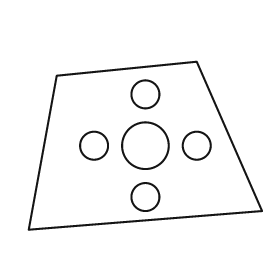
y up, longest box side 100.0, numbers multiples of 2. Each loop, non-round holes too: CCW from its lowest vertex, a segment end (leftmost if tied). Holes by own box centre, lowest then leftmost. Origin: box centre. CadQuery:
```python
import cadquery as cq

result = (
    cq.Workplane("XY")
    .moveTo(-50.0, -36.0)
    .lineTo(50.0, -28.0)
    .lineTo(22.0, 36.0)
    .lineTo(-38.0, 30.0)
    .close()
    .moveTo(0.0, -22.0)
    .circle(6.0)
    .moveTo(-22.0, 0.0)
    .circle(6.0)
    .moveTo(0.0, 0.0)
    .circle(10.0)
    .moveTo(22.0, 0.0)
    .circle(6.0)
    .moveTo(0.0, 22.0)
    .circle(6.0)
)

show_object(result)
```